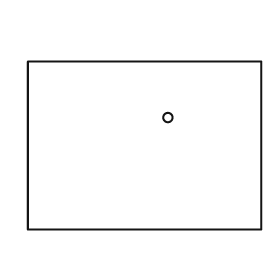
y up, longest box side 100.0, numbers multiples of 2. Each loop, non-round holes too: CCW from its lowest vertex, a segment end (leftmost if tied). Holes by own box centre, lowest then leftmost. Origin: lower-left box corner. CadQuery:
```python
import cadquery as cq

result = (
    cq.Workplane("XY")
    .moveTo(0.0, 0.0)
    .lineTo(100.0, 0.0)
    .lineTo(100.0, 72.0)
    .lineTo(0.0, 72.0)
    .close()
    .moveTo(60.0, 48.0)
    .circle(2.0)
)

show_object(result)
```